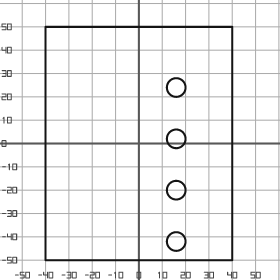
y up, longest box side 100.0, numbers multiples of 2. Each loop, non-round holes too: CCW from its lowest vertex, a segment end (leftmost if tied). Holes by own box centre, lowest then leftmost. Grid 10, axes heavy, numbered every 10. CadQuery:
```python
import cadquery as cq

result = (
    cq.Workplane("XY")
    .moveTo(-40.0, -50.0)
    .lineTo(40.0, -50.0)
    .lineTo(40.0, 50.0)
    .lineTo(-40.0, 50.0)
    .close()
    .moveTo(16.0, -42.0)
    .circle(4.0)
    .moveTo(16.0, -20.0)
    .circle(4.0)
    .moveTo(16.0, 2.0)
    .circle(4.0)
    .moveTo(16.0, 24.0)
    .circle(4.0)
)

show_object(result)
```